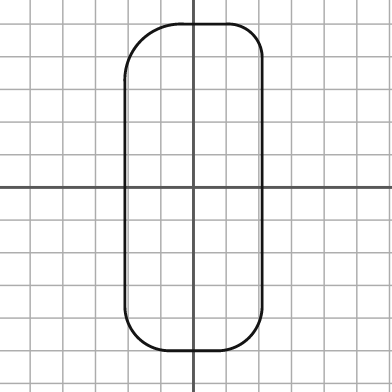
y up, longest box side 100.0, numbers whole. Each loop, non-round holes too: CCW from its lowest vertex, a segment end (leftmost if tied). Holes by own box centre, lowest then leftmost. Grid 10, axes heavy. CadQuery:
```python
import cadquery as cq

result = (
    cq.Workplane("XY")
    .moveTo(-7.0, -50.0)
    .lineTo(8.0, -50.0)
    .threePointArc((17.0, -46.0), (21.0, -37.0))
    .lineTo(21.0, 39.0)
    .threePointArc((18.0, 47.0), (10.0, 50.0))
    .lineTo(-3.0, 50.0)
    .threePointArc((-16.0, 45.0), (-21.0, 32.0))
    .lineTo(-21.0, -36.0)
    .threePointArc((-17.0, -46.0), (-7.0, -50.0))
    .close()
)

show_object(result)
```